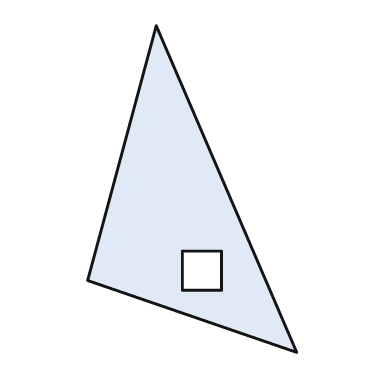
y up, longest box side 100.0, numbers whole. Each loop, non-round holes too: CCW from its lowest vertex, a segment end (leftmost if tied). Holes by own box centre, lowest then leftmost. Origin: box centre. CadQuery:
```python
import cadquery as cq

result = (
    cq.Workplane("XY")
    .moveTo(32.0, -50.0)
    .lineTo(-11.0, 50.0)
    .lineTo(-32.0, -28.0)
    .close()
    .moveTo(-3.0, -31.0)
    .lineTo(9.0, -31.0)
    .lineTo(9.0, -19.0)
    .lineTo(-3.0, -19.0)
    .close()
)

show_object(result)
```